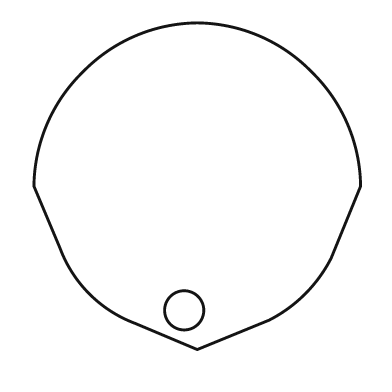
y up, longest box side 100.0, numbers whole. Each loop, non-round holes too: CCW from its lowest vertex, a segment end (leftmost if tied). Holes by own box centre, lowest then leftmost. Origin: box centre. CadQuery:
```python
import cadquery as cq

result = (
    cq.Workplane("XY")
    .moveTo(0.0, -50.0)
    .lineTo(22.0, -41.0)
    .threePointArc((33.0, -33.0), (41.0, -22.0))
    .lineTo(50.0, 0.0)
    .threePointArc((46.0, 19.0), (35.0, 35.0))
    .threePointArc((19.0, 46.0), (0.0, 50.0))
    .threePointArc((-19.0, 46.0), (-35.0, 35.0))
    .threePointArc((-46.0, 19.0), (-50.0, 0.0))
    .lineTo(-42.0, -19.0)
    .threePointArc((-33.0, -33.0), (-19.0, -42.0))
    .close()
    .moveTo(-4.0, -38.0)
    .circle(6.0)
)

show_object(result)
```